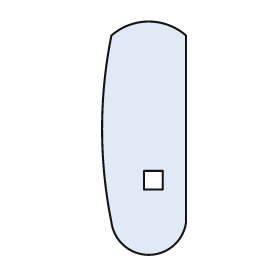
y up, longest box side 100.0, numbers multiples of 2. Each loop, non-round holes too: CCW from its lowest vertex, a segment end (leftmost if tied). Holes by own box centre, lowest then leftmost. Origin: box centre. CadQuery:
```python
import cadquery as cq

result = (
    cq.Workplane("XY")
    .moveTo(-14.0, -36.0)
    .threePointArc((2.0, -50.0), (18.0, -36.0))
    .lineTo(18.0, 44.0)
    .threePointArc((2.0, 50.0), (-14.0, 44.0))
    .threePointArc((-18.0, 4.0), (-14.0, -36.0))
    .close()
    .moveTo(0.0, -22.0)
    .lineTo(8.0, -22.0)
    .lineTo(8.0, -14.0)
    .lineTo(0.0, -14.0)
    .close()
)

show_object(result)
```